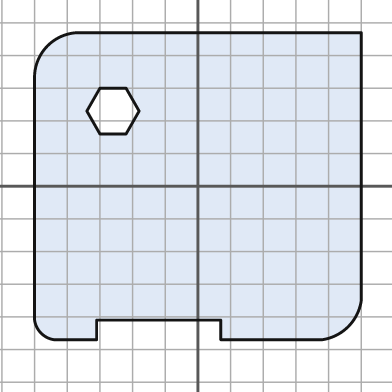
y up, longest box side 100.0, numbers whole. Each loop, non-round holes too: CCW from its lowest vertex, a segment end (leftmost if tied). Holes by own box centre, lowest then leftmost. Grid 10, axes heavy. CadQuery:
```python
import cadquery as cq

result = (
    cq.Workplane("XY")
    .moveTo(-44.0, -47.0)
    .lineTo(-31.0, -47.0)
    .lineTo(-31.0, -41.0)
    .lineTo(7.0, -41.0)
    .lineTo(7.0, -47.0)
    .lineTo(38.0, -47.0)
    .threePointArc((46.0, -43.0), (50.0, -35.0))
    .lineTo(50.0, 47.0)
    .lineTo(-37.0, 47.0)
    .threePointArc((-46.0, 43.0), (-50.0, 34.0))
    .lineTo(-50.0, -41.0)
    .threePointArc((-48.0, -45.0), (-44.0, -47.0))
    .close()
    .moveTo(-30.0, 16.0)
    .lineTo(-22.0, 16.0)
    .lineTo(-18.0, 23.0)
    .lineTo(-22.0, 30.0)
    .lineTo(-30.0, 30.0)
    .lineTo(-34.0, 23.0)
    .close()
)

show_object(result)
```